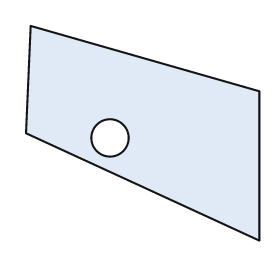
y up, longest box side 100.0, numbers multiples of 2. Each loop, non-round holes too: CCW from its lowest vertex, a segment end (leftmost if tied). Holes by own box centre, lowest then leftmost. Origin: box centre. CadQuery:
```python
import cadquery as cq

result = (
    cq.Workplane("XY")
    .moveTo(50.0, -46.0)
    .lineTo(50.0, 18.0)
    .lineTo(-48.0, 46.0)
    .lineTo(-50.0, 0.0)
    .close()
    .moveTo(-14.0, -2.0)
    .circle(8.0)
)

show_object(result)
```